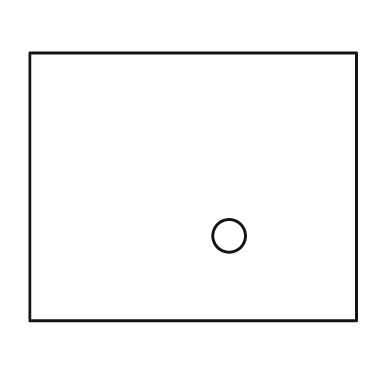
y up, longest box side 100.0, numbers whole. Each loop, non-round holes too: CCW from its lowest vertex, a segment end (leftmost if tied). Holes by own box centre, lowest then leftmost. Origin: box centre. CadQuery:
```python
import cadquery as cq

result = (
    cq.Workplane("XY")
    .moveTo(-50.0, -41.0)
    .lineTo(50.0, -41.0)
    .lineTo(50.0, 41.0)
    .lineTo(-50.0, 41.0)
    .close()
    .moveTo(11.0, -15.0)
    .circle(5.0)
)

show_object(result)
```